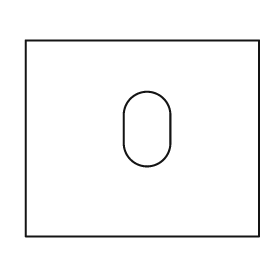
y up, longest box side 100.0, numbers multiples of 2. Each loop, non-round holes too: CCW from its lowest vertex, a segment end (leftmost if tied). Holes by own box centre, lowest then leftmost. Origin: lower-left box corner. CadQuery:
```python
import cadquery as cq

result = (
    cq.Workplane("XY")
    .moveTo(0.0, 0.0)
    .lineTo(100.0, 0.0)
    .lineTo(100.0, 84.0)
    .lineTo(0.0, 84.0)
    .close()
    .moveTo(42.0, 40.0)
    .threePointArc((52.0, 30.0), (62.0, 40.0))
    .lineTo(62.0, 52.0)
    .threePointArc((52.0, 62.0), (42.0, 52.0))
    .close()
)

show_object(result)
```